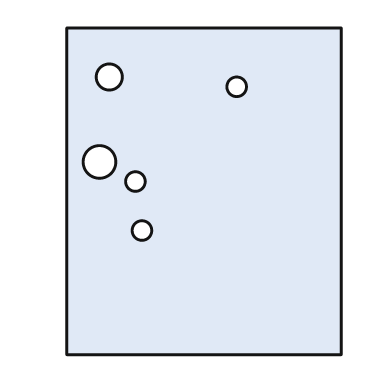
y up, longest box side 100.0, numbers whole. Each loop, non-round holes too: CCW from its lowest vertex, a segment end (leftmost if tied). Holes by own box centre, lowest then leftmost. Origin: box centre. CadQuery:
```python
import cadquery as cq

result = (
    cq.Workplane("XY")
    .moveTo(-42.0, -50.0)
    .lineTo(42.0, -50.0)
    .lineTo(42.0, 50.0)
    .lineTo(-42.0, 50.0)
    .close()
    .moveTo(-19.0, -12.0)
    .circle(3.0)
    .moveTo(-21.0, 3.0)
    .circle(3.0)
    .moveTo(-32.0, 9.0)
    .circle(5.0)
    .moveTo(10.0, 32.0)
    .circle(3.0)
    .moveTo(-29.0, 35.0)
    .circle(4.0)
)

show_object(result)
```